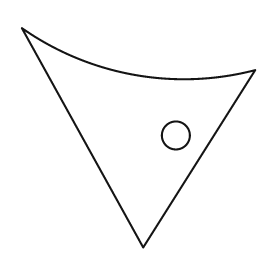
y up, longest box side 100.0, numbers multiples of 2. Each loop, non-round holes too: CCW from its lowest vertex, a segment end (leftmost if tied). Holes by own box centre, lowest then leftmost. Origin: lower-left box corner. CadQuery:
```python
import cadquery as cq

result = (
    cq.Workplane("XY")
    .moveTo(52.0, 0.0)
    .lineTo(100.0, 76.0)
    .threePointArc((48.0, 74.0), (0.0, 94.0))
    .close()
    .moveTo(66.0, 48.0)
    .circle(6.0)
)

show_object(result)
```